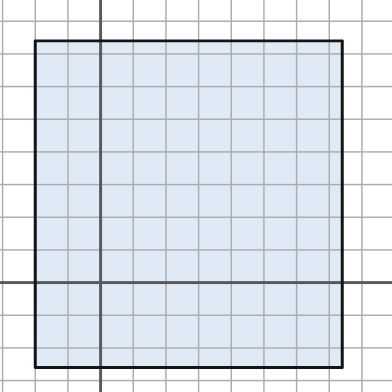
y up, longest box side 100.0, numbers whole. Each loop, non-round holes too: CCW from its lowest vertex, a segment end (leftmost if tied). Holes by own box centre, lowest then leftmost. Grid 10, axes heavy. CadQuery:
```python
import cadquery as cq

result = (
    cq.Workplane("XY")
    .moveTo(-20.0, -26.0)
    .lineTo(74.0, -26.0)
    .lineTo(74.0, 74.0)
    .lineTo(-20.0, 74.0)
    .close()
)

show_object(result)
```